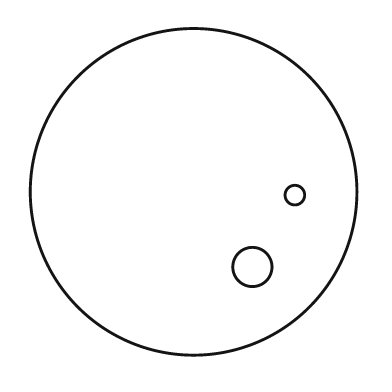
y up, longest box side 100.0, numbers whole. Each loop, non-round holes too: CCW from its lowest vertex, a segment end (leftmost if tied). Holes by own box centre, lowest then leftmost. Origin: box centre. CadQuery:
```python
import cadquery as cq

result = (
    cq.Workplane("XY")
    .moveTo(0.0, 0.0)
    .circle(50.0)
    .moveTo(18.0, -23.0)
    .circle(6.0)
    .moveTo(31.0, -1.0)
    .circle(3.0)
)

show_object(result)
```